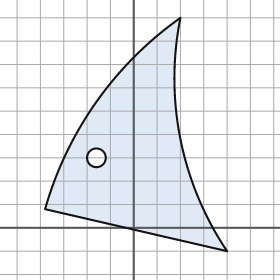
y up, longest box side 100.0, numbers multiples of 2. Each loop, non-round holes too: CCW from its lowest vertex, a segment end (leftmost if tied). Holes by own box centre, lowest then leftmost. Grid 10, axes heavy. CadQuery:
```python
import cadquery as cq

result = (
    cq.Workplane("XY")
    .moveTo(40.0, -10.0)
    .threePointArc((20.0, 38.0), (20.0, 90.0))
    .threePointArc((-16.0, 54.0), (-38.0, 8.0))
    .close()
    .moveTo(-16.0, 30.0)
    .circle(4.0)
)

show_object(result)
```